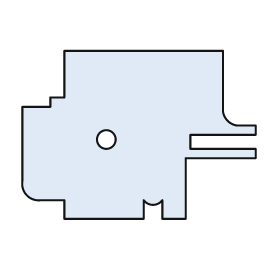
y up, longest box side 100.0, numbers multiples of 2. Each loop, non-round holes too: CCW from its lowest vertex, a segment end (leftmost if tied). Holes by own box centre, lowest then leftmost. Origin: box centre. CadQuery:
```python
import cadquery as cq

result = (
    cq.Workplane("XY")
    .moveTo(-32.0, -36.0)
    .lineTo(2.0, -36.0)
    .lineTo(2.0, -28.0)
    .threePointArc((6.0, -30.0), (10.0, -28.0))
    .lineTo(10.0, -36.0)
    .lineTo(20.0, -36.0)
    .lineTo(20.0, -10.0)
    .lineTo(50.0, -10.0)
    .lineTo(50.0, -6.0)
    .lineTo(22.0, -6.0)
    .lineTo(22.0, 0.0)
    .lineTo(50.0, 0.0)
    .lineTo(50.0, 4.0)
    .lineTo(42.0, 4.0)
    .threePointArc((38.0, 6.0), (36.0, 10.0))
    .lineTo(36.0, 36.0)
    .lineTo(-32.0, 36.0)
    .lineTo(-32.0, 16.0)
    .lineTo(-38.0, 16.0)
    .lineTo(-38.0, 12.0)
    .lineTo(-50.0, 12.0)
    .lineTo(-50.0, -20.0)
    .threePointArc((-48.0, -26.0), (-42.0, -28.0))
    .lineTo(-32.0, -28.0)
    .close()
    .moveTo(-14.0, -2.0)
    .circle(4.0)
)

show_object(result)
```